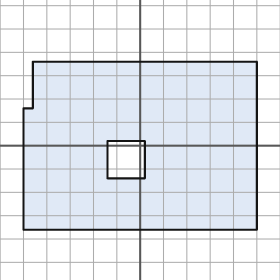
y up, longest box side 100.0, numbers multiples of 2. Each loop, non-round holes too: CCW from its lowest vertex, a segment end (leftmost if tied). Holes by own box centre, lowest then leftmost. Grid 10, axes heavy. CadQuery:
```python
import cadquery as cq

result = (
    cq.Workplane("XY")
    .moveTo(-50.0, -36.0)
    .lineTo(50.0, -36.0)
    .lineTo(50.0, 36.0)
    .lineTo(-46.0, 36.0)
    .lineTo(-46.0, 16.0)
    .lineTo(-50.0, 16.0)
    .close()
    .moveTo(-14.0, -14.0)
    .lineTo(2.0, -14.0)
    .lineTo(2.0, 2.0)
    .lineTo(-14.0, 2.0)
    .close()
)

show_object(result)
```